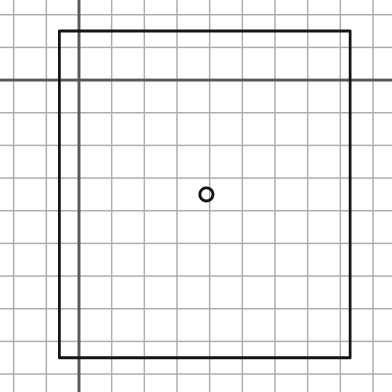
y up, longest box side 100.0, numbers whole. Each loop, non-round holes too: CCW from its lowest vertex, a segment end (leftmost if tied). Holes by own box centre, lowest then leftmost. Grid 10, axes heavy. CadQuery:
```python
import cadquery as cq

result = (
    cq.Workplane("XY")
    .moveTo(-6.0, -85.0)
    .lineTo(83.0, -85.0)
    .lineTo(83.0, 15.0)
    .lineTo(-6.0, 15.0)
    .close()
    .moveTo(39.0, -35.0)
    .circle(2.0)
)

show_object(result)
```